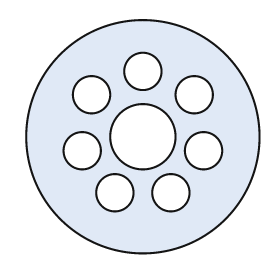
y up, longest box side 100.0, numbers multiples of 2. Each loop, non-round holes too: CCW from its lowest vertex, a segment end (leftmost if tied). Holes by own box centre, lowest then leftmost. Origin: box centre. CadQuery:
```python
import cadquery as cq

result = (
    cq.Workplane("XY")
    .moveTo(0.0, 0.0)
    .circle(50.0)
    .moveTo(-12.0, -24.0)
    .circle(8.0)
    .moveTo(12.0, -24.0)
    .circle(8.0)
    .moveTo(-26.0, -6.0)
    .circle(8.0)
    .moveTo(26.0, -6.0)
    .circle(8.0)
    .moveTo(0.0, 0.0)
    .circle(14.0)
    .moveTo(-22.0, 18.0)
    .circle(8.0)
    .moveTo(22.0, 18.0)
    .circle(8.0)
    .moveTo(0.0, 28.0)
    .circle(8.0)
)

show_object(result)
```